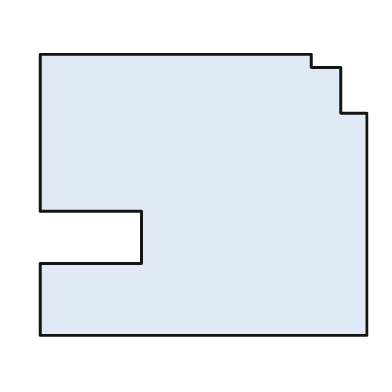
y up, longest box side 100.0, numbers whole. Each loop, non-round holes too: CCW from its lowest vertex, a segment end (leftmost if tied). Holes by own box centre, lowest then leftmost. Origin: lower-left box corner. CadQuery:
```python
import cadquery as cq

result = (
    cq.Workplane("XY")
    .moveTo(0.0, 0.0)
    .lineTo(100.0, 0.0)
    .lineTo(100.0, 68.0)
    .lineTo(92.0, 68.0)
    .lineTo(92.0, 82.0)
    .lineTo(83.0, 82.0)
    .lineTo(83.0, 86.0)
    .lineTo(0.0, 86.0)
    .lineTo(0.0, 38.0)
    .lineTo(31.0, 38.0)
    .lineTo(31.0, 22.0)
    .lineTo(0.0, 22.0)
    .close()
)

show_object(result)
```